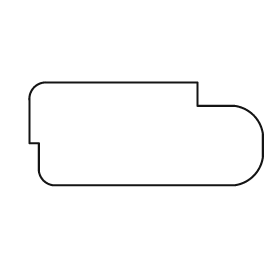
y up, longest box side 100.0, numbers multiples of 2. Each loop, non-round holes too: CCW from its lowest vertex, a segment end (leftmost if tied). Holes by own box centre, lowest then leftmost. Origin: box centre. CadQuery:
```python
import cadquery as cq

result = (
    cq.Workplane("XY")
    .moveTo(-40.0, -22.0)
    .lineTo(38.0, -22.0)
    .threePointArc((46.0, -18.0), (50.0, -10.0))
    .lineTo(50.0, 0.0)
    .threePointArc((46.0, 8.0), (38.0, 12.0))
    .lineTo(22.0, 12.0)
    .lineTo(22.0, 22.0)
    .lineTo(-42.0, 22.0)
    .threePointArc((-48.0, 20.0), (-50.0, 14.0))
    .lineTo(-50.0, -4.0)
    .lineTo(-46.0, -4.0)
    .lineTo(-46.0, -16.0)
    .threePointArc((-44.0, -20.0), (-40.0, -22.0))
    .close()
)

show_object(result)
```